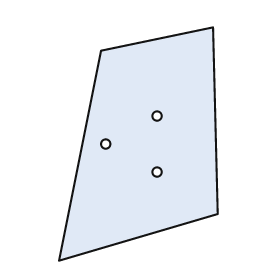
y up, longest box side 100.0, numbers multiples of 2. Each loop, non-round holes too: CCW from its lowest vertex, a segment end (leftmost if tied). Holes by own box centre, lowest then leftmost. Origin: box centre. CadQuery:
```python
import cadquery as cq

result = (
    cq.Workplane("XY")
    .moveTo(-34.0, -50.0)
    .lineTo(34.0, -30.0)
    .lineTo(32.0, 50.0)
    .lineTo(-16.0, 40.0)
    .close()
    .moveTo(8.0, -12.0)
    .circle(2.0)
    .moveTo(-14.0, 0.0)
    .circle(2.0)
    .moveTo(8.0, 12.0)
    .circle(2.0)
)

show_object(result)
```